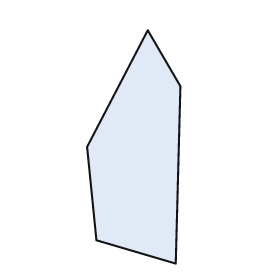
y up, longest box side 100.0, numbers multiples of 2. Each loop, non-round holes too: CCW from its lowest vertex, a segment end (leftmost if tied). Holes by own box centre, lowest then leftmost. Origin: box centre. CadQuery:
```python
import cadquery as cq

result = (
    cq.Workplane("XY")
    .moveTo(18.0, -50.0)
    .lineTo(20.0, 26.0)
    .lineTo(6.0, 50.0)
    .lineTo(-20.0, 0.0)
    .lineTo(-16.0, -40.0)
    .close()
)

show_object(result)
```